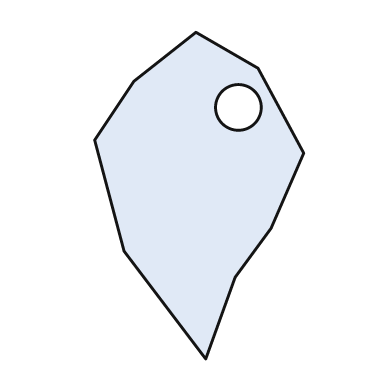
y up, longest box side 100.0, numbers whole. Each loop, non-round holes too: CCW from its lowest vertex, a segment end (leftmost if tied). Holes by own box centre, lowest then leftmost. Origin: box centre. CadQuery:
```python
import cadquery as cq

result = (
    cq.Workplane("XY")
    .moveTo(2.0, -50.0)
    .lineTo(11.0, -25.0)
    .lineTo(22.0, -10.0)
    .lineTo(32.0, 13.0)
    .lineTo(18.0, 39.0)
    .lineTo(-1.0, 50.0)
    .lineTo(-20.0, 35.0)
    .lineTo(-32.0, 17.0)
    .lineTo(-23.0, -17.0)
    .close()
    .moveTo(12.0, 27.0)
    .circle(7.0)
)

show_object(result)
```